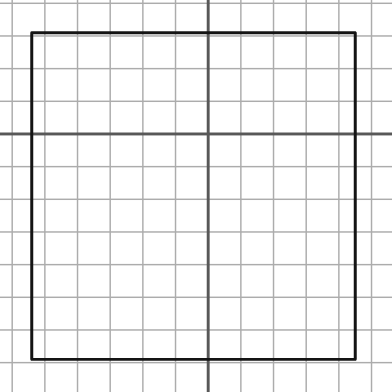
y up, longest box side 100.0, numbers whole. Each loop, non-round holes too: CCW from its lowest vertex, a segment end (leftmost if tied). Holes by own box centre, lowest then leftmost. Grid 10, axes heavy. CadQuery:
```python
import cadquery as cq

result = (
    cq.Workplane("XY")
    .moveTo(-54.0, -69.0)
    .lineTo(45.0, -69.0)
    .lineTo(45.0, 31.0)
    .lineTo(-54.0, 31.0)
    .close()
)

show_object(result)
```